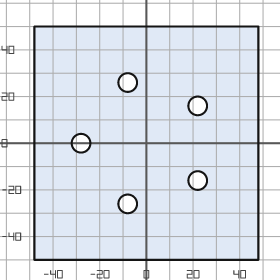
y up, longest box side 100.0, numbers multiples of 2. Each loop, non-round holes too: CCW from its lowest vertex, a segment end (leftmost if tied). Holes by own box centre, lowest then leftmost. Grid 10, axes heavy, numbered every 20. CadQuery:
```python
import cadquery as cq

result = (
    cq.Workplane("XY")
    .moveTo(-48.0, -50.0)
    .lineTo(48.0, -50.0)
    .lineTo(48.0, 50.0)
    .lineTo(-48.0, 50.0)
    .close()
    .moveTo(-8.0, -26.0)
    .circle(4.0)
    .moveTo(22.0, -16.0)
    .circle(4.0)
    .moveTo(-28.0, 0.0)
    .circle(4.0)
    .moveTo(22.0, 16.0)
    .circle(4.0)
    .moveTo(-8.0, 26.0)
    .circle(4.0)
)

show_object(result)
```